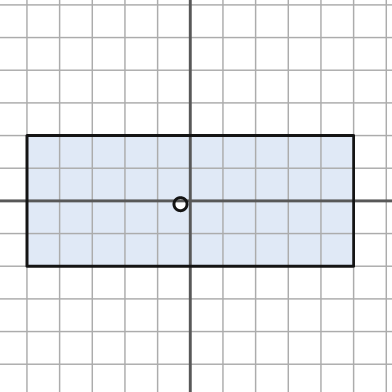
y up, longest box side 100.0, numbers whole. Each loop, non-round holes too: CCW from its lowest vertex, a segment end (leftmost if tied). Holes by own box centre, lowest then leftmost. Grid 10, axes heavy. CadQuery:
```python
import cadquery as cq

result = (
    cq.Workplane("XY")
    .moveTo(-50.0, -20.0)
    .lineTo(50.0, -20.0)
    .lineTo(50.0, 20.0)
    .lineTo(-50.0, 20.0)
    .close()
    .moveTo(-3.0, -1.0)
    .circle(2.0)
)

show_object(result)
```